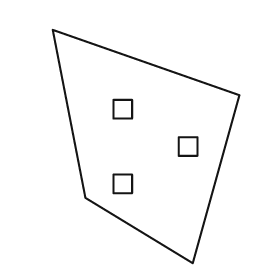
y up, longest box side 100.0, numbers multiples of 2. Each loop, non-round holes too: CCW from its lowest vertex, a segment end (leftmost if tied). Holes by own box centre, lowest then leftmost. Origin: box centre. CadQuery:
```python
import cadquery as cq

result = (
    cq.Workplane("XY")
    .moveTo(20.0, -50.0)
    .lineTo(40.0, 22.0)
    .lineTo(-40.0, 50.0)
    .lineTo(-26.0, -22.0)
    .close()
    .moveTo(-14.0, -20.0)
    .lineTo(-6.0, -20.0)
    .lineTo(-6.0, -12.0)
    .lineTo(-14.0, -12.0)
    .close()
    .moveTo(14.0, -4.0)
    .lineTo(22.0, -4.0)
    .lineTo(22.0, 4.0)
    .lineTo(14.0, 4.0)
    .close()
    .moveTo(-14.0, 12.0)
    .lineTo(-6.0, 12.0)
    .lineTo(-6.0, 20.0)
    .lineTo(-14.0, 20.0)
    .close()
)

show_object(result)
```